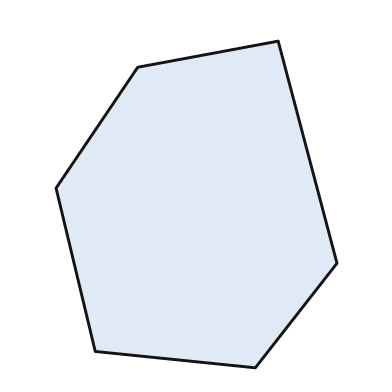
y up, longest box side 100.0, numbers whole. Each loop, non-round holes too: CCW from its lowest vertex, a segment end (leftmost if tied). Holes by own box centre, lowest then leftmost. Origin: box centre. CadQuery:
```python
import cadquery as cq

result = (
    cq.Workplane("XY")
    .moveTo(18.0, -50.0)
    .lineTo(43.0, -18.0)
    .lineTo(25.0, 50.0)
    .lineTo(-18.0, 42.0)
    .lineTo(-43.0, 5.0)
    .lineTo(-31.0, -45.0)
    .close()
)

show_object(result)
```